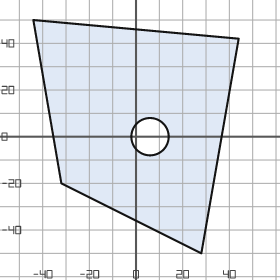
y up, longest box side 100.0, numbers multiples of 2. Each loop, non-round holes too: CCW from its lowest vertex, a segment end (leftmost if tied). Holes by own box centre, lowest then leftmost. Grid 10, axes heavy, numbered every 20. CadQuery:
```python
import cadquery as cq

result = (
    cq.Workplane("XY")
    .moveTo(28.0, -50.0)
    .lineTo(44.0, 42.0)
    .lineTo(-44.0, 50.0)
    .lineTo(-32.0, -20.0)
    .close()
    .moveTo(6.0, 0.0)
    .circle(8.0)
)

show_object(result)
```